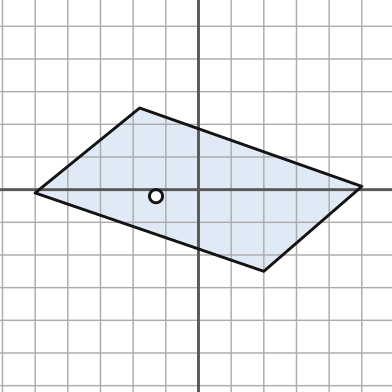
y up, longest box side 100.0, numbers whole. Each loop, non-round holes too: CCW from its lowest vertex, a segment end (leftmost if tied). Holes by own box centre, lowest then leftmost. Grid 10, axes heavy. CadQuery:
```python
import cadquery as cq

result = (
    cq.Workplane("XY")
    .moveTo(20.0, -25.0)
    .lineTo(50.0, 1.0)
    .lineTo(-18.0, 25.0)
    .lineTo(-50.0, -1.0)
    .close()
    .moveTo(-13.0, -2.0)
    .circle(2.0)
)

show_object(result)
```